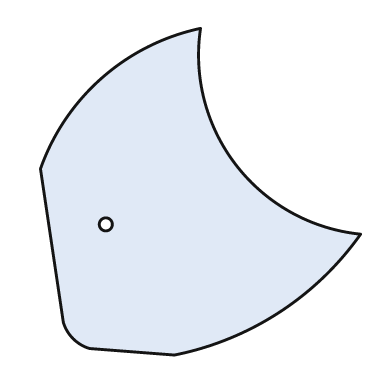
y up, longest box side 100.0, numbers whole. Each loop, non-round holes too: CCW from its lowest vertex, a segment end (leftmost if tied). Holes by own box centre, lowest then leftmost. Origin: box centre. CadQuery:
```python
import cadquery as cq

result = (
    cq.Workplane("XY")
    .moveTo(-8.0, -50.0)
    .threePointArc((24.0, -37.0), (49.0, -13.0))
    .threePointArc((11.0, 8.0), (0.0, 50.0))
    .threePointArc((-30.0, 35.0), (-49.0, 7.0))
    .lineTo(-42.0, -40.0)
    .threePointArc((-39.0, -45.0), (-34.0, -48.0))
    .close()
    .moveTo(-29.0, -10.0)
    .circle(2.0)
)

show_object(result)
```